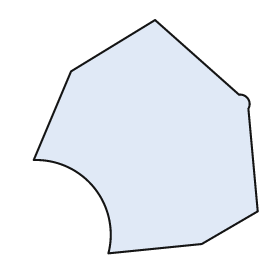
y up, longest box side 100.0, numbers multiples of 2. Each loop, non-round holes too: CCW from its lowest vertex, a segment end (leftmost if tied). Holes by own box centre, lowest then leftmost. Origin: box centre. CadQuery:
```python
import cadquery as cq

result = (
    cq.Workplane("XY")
    .moveTo(-16.0, -50.0)
    .lineTo(24.0, -46.0)
    .lineTo(48.0, -32.0)
    .lineTo(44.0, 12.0)
    .threePointArc((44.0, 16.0), (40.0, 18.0))
    .lineTo(4.0, 50.0)
    .lineTo(-32.0, 28.0)
    .lineTo(-48.0, -10.0)
    .threePointArc((-22.0, -22.0), (-16.0, -50.0))
    .close()
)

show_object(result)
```